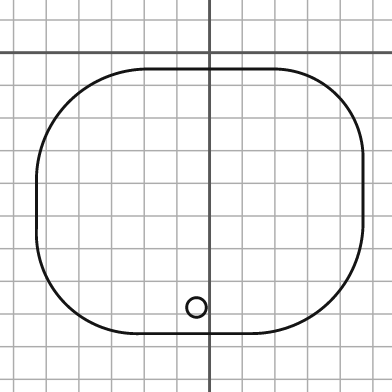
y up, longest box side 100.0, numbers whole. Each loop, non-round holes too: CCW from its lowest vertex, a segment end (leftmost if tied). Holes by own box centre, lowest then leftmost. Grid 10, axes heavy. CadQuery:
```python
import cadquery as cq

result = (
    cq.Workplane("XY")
    .moveTo(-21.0, -86.0)
    .lineTo(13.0, -86.0)
    .threePointArc((37.0, -76.0), (47.0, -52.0))
    .lineTo(47.0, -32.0)
    .threePointArc((39.0, -13.0), (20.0, -5.0))
    .lineTo(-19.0, -5.0)
    .threePointArc((-43.0, -15.0), (-53.0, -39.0))
    .lineTo(-53.0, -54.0)
    .threePointArc((-44.0, -77.0), (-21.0, -86.0))
    .close()
    .moveTo(-4.0, -78.0)
    .circle(3.0)
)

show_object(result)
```